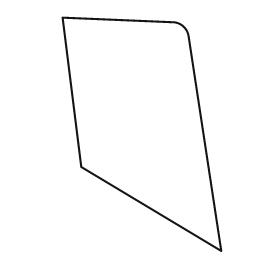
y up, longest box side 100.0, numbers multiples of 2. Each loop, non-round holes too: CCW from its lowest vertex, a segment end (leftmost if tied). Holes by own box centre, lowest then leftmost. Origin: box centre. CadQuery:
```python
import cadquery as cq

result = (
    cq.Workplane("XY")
    .moveTo(34.0, -50.0)
    .lineTo(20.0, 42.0)
    .threePointArc((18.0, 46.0), (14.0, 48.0))
    .lineTo(-34.0, 50.0)
    .lineTo(-26.0, -14.0)
    .close()
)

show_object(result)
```